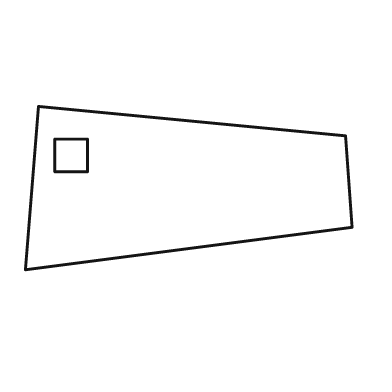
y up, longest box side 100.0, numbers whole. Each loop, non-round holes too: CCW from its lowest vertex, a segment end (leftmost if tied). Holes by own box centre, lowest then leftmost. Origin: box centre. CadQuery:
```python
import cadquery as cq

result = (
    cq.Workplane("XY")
    .moveTo(-50.0, -25.0)
    .lineTo(50.0, -12.0)
    .lineTo(48.0, 16.0)
    .lineTo(-46.0, 25.0)
    .close()
    .moveTo(-41.0, 5.0)
    .lineTo(-31.0, 5.0)
    .lineTo(-31.0, 15.0)
    .lineTo(-41.0, 15.0)
    .close()
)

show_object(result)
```